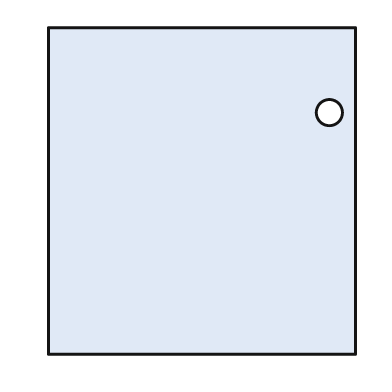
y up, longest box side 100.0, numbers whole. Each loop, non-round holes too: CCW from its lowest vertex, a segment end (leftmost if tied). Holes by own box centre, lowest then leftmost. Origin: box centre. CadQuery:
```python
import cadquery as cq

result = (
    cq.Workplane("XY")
    .moveTo(-47.0, -50.0)
    .lineTo(47.0, -50.0)
    .lineTo(47.0, 50.0)
    .lineTo(-47.0, 50.0)
    .close()
    .moveTo(39.0, 24.0)
    .circle(4.0)
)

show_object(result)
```